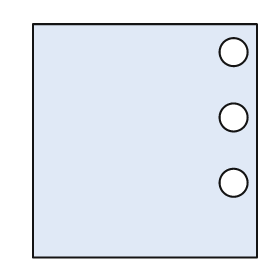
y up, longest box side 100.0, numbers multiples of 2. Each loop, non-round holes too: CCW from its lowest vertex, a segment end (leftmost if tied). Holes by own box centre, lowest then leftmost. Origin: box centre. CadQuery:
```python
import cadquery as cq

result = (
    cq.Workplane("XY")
    .moveTo(-48.0, -50.0)
    .lineTo(48.0, -50.0)
    .lineTo(48.0, 50.0)
    .lineTo(-48.0, 50.0)
    .close()
    .moveTo(38.0, -18.0)
    .circle(6.0)
    .moveTo(38.0, 10.0)
    .circle(6.0)
    .moveTo(38.0, 38.0)
    .circle(6.0)
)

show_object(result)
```